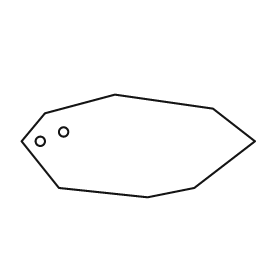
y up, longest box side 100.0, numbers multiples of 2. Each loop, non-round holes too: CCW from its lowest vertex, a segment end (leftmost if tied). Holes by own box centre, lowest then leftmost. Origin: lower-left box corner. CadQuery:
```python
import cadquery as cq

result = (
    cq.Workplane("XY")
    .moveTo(54.0, 0.0)
    .lineTo(74.0, 4.0)
    .lineTo(100.0, 24.0)
    .lineTo(82.0, 38.0)
    .lineTo(40.0, 44.0)
    .lineTo(10.0, 36.0)
    .lineTo(0.0, 24.0)
    .lineTo(16.0, 4.0)
    .close()
    .moveTo(8.0, 24.0)
    .circle(2.0)
    .moveTo(18.0, 28.0)
    .circle(2.0)
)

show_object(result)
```